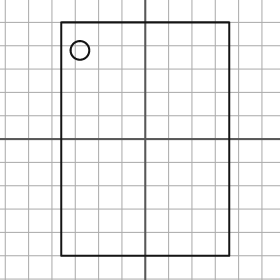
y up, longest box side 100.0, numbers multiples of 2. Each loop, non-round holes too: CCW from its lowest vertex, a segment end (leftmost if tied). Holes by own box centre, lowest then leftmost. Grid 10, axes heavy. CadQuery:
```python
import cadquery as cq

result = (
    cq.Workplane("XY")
    .moveTo(-36.0, -50.0)
    .lineTo(36.0, -50.0)
    .lineTo(36.0, 50.0)
    .lineTo(-36.0, 50.0)
    .close()
    .moveTo(-28.0, 38.0)
    .circle(4.0)
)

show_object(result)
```